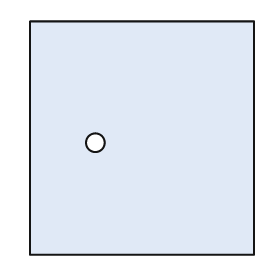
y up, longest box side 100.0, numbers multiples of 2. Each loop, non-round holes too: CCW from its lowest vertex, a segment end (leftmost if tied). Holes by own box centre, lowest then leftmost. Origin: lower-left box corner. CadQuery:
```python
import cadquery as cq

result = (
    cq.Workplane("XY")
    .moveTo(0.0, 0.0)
    .lineTo(96.0, 0.0)
    .lineTo(96.0, 100.0)
    .lineTo(0.0, 100.0)
    .close()
    .moveTo(28.0, 48.0)
    .circle(4.0)
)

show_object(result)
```